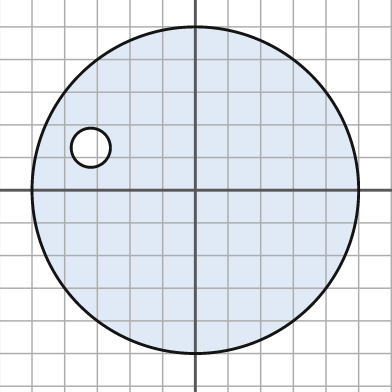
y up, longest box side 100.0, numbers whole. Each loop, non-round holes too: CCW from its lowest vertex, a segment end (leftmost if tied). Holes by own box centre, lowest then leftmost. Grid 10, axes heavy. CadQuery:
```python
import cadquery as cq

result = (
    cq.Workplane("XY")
    .moveTo(0.0, 0.0)
    .circle(50.0)
    .moveTo(-32.0, 13.0)
    .circle(6.0)
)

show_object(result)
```